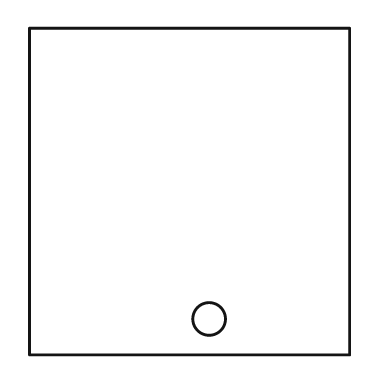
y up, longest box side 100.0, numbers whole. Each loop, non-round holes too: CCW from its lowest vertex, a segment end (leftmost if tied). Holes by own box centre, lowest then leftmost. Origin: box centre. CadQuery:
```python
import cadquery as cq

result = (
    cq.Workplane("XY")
    .moveTo(-49.0, -50.0)
    .lineTo(49.0, -50.0)
    .lineTo(49.0, 50.0)
    .lineTo(-49.0, 50.0)
    .close()
    .moveTo(6.0, -39.0)
    .circle(5.0)
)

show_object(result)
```